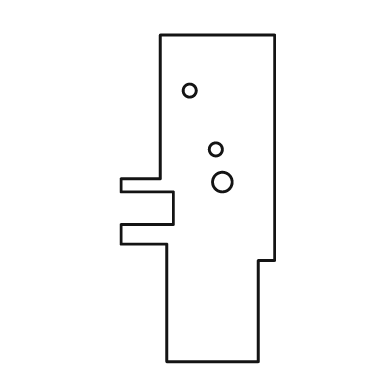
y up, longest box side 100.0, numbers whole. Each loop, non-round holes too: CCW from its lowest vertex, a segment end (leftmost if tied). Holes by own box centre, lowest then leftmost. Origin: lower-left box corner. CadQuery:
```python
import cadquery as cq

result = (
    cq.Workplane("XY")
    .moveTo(14.0, 0.0)
    .lineTo(42.0, 0.0)
    .lineTo(42.0, 31.0)
    .lineTo(47.0, 31.0)
    .lineTo(47.0, 100.0)
    .lineTo(12.0, 100.0)
    .lineTo(12.0, 56.0)
    .lineTo(0.0, 56.0)
    .lineTo(0.0, 52.0)
    .lineTo(16.0, 52.0)
    .lineTo(16.0, 42.0)
    .lineTo(0.0, 42.0)
    .lineTo(0.0, 36.0)
    .lineTo(14.0, 36.0)
    .close()
    .moveTo(31.0, 55.0)
    .circle(3.0)
    .moveTo(29.0, 65.0)
    .circle(2.0)
    .moveTo(21.0, 83.0)
    .circle(2.0)
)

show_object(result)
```